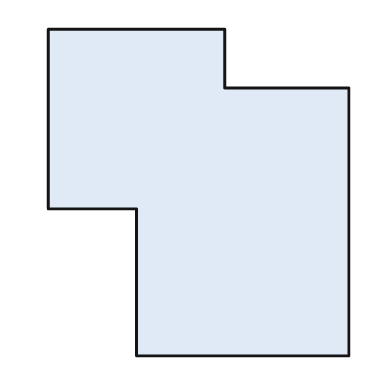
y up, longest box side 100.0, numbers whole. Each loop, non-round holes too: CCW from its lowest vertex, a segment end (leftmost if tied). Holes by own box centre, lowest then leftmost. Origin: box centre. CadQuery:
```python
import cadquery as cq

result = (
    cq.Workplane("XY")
    .moveTo(-19.0, -50.0)
    .lineTo(46.0, -50.0)
    .lineTo(46.0, 32.0)
    .lineTo(8.0, 32.0)
    .lineTo(8.0, 50.0)
    .lineTo(-46.0, 50.0)
    .lineTo(-46.0, -5.0)
    .lineTo(-19.0, -5.0)
    .close()
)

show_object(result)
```